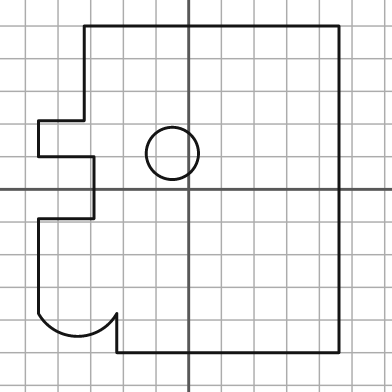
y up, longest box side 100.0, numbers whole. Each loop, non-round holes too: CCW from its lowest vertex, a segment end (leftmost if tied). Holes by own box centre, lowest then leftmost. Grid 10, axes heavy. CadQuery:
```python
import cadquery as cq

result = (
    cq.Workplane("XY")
    .moveTo(-22.0, -50.0)
    .lineTo(46.0, -50.0)
    .lineTo(46.0, 50.0)
    .lineTo(-32.0, 50.0)
    .lineTo(-32.0, 21.0)
    .lineTo(-46.0, 21.0)
    .lineTo(-46.0, 10.0)
    .lineTo(-29.0, 10.0)
    .lineTo(-29.0, -9.0)
    .lineTo(-46.0, -9.0)
    .lineTo(-46.0, -38.0)
    .threePointArc((-34.0, -45.0), (-22.0, -38.0))
    .close()
    .moveTo(-5.0, 11.0)
    .circle(8.0)
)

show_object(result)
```